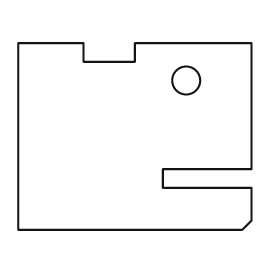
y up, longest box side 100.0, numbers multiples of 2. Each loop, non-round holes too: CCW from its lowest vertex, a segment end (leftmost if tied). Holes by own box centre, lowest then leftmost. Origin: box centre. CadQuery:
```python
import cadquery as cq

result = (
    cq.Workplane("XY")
    .moveTo(-50.0, -40.0)
    .lineTo(46.0, -40.0)
    .lineTo(50.0, -36.0)
    .lineTo(50.0, -22.0)
    .lineTo(12.0, -22.0)
    .lineTo(12.0, -14.0)
    .lineTo(50.0, -14.0)
    .lineTo(50.0, 40.0)
    .lineTo(0.0, 40.0)
    .lineTo(0.0, 32.0)
    .lineTo(-22.0, 32.0)
    .lineTo(-22.0, 40.0)
    .lineTo(-50.0, 40.0)
    .close()
    .moveTo(22.0, 24.0)
    .circle(6.0)
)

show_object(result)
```